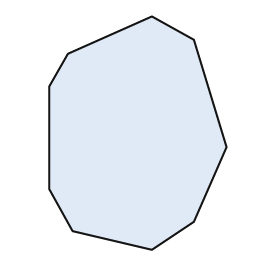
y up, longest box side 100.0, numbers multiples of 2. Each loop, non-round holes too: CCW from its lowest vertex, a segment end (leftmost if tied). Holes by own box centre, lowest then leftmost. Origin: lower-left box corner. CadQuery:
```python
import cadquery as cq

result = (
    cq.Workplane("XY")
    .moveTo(44.0, 0.0)
    .lineTo(62.0, 12.0)
    .lineTo(76.0, 44.0)
    .lineTo(62.0, 90.0)
    .lineTo(44.0, 100.0)
    .lineTo(8.0, 84.0)
    .lineTo(0.0, 70.0)
    .lineTo(0.0, 26.0)
    .lineTo(10.0, 8.0)
    .close()
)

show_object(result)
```